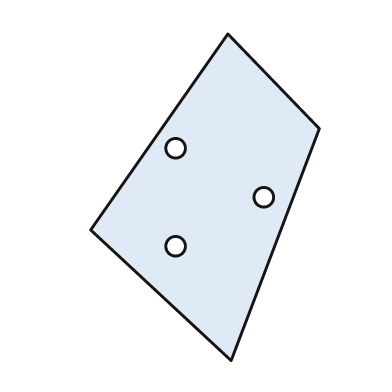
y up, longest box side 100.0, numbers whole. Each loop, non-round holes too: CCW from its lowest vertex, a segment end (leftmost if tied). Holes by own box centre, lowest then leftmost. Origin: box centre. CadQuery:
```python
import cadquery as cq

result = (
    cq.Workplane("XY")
    .moveTo(8.0, -50.0)
    .lineTo(35.0, 21.0)
    .lineTo(7.0, 50.0)
    .lineTo(-35.0, -10.0)
    .close()
    .moveTo(-9.0, -15.0)
    .circle(3.0)
    .moveTo(18.0, 0.0)
    .circle(3.0)
    .moveTo(-9.0, 15.0)
    .circle(3.0)
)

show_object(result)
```